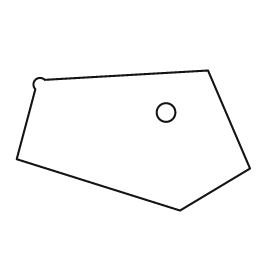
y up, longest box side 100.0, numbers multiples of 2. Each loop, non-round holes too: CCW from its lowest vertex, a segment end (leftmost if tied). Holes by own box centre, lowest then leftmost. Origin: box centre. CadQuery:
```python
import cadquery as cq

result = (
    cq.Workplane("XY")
    .moveTo(20.0, -30.0)
    .lineTo(50.0, -12.0)
    .lineTo(32.0, 30.0)
    .lineTo(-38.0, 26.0)
    .threePointArc((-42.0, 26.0), (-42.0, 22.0))
    .lineTo(-50.0, -8.0)
    .close()
    .moveTo(14.0, 12.0)
    .circle(4.0)
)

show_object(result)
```